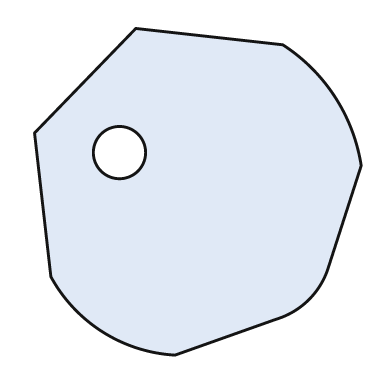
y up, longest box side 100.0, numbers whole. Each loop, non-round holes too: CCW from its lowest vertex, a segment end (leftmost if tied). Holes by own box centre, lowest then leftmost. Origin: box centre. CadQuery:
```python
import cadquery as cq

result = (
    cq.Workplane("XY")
    .moveTo(-7.0, -50.0)
    .lineTo(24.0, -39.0)
    .threePointArc((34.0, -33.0), (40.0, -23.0))
    .lineTo(50.0, 8.0)
    .threePointArc((42.0, 29.0), (26.0, 45.0))
    .lineTo(-19.0, 50.0)
    .lineTo(-50.0, 18.0)
    .lineTo(-45.0, -26.0)
    .threePointArc((-29.0, -43.0), (-7.0, -50.0))
    .close()
    .moveTo(-24.0, 12.0)
    .circle(8.0)
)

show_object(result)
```